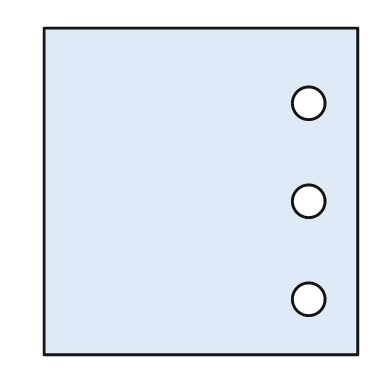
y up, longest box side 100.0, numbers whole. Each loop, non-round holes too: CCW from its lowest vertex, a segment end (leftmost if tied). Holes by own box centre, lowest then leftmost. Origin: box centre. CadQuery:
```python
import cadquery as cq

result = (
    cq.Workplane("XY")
    .moveTo(-48.0, -50.0)
    .lineTo(48.0, -50.0)
    .lineTo(48.0, 50.0)
    .lineTo(-48.0, 50.0)
    .close()
    .moveTo(33.0, -33.0)
    .circle(5.0)
    .moveTo(33.0, -3.0)
    .circle(5.0)
    .moveTo(33.0, 27.0)
    .circle(5.0)
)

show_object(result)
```